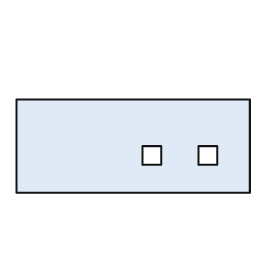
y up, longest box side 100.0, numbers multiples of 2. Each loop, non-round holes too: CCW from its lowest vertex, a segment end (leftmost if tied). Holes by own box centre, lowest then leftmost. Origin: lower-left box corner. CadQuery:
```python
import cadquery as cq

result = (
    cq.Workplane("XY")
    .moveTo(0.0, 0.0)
    .lineTo(100.0, 0.0)
    .lineTo(100.0, 40.0)
    .lineTo(0.0, 40.0)
    .close()
    .moveTo(54.0, 12.0)
    .lineTo(62.0, 12.0)
    .lineTo(62.0, 20.0)
    .lineTo(54.0, 20.0)
    .close()
    .moveTo(78.0, 12.0)
    .lineTo(86.0, 12.0)
    .lineTo(86.0, 20.0)
    .lineTo(78.0, 20.0)
    .close()
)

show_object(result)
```